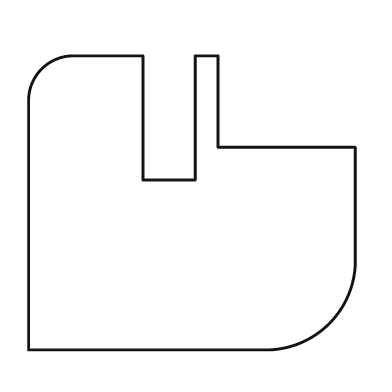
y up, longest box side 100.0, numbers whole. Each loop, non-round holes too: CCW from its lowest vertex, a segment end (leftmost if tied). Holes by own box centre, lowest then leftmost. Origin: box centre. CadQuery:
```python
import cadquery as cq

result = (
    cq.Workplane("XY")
    .moveTo(-50.0, -45.0)
    .lineTo(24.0, -45.0)
    .threePointArc((42.0, -37.0), (50.0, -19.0))
    .lineTo(50.0, 17.0)
    .lineTo(8.0, 17.0)
    .lineTo(8.0, 45.0)
    .lineTo(1.0, 45.0)
    .lineTo(1.0, 7.0)
    .lineTo(-15.0, 7.0)
    .lineTo(-15.0, 45.0)
    .lineTo(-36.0, 45.0)
    .threePointArc((-46.0, 41.0), (-50.0, 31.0))
    .close()
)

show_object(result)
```